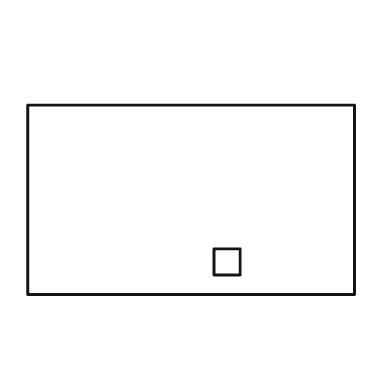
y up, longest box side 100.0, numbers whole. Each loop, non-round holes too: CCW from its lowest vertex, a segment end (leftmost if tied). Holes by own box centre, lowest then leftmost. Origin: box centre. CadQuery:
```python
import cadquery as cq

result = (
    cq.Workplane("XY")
    .moveTo(-50.0, -29.0)
    .lineTo(50.0, -29.0)
    .lineTo(50.0, 29.0)
    .lineTo(-50.0, 29.0)
    .close()
    .moveTo(7.0, -23.0)
    .lineTo(15.0, -23.0)
    .lineTo(15.0, -15.0)
    .lineTo(7.0, -15.0)
    .close()
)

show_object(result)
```